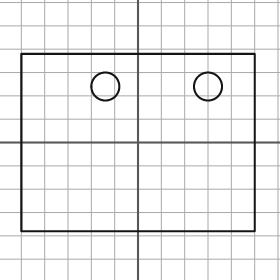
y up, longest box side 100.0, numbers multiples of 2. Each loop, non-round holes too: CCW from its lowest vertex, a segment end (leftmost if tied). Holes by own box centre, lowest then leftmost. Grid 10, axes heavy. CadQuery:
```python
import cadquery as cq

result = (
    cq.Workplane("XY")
    .moveTo(-50.0, -38.0)
    .lineTo(50.0, -38.0)
    .lineTo(50.0, 38.0)
    .lineTo(-50.0, 38.0)
    .close()
    .moveTo(-14.0, 24.0)
    .circle(6.0)
    .moveTo(30.0, 24.0)
    .circle(6.0)
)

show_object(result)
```